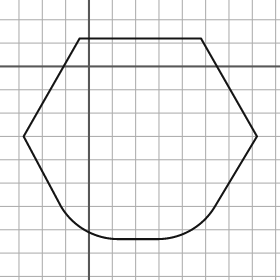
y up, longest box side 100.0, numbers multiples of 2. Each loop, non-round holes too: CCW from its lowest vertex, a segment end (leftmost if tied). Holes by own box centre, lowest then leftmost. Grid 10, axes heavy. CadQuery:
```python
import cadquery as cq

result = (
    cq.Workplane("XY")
    .moveTo(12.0, -74.0)
    .lineTo(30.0, -74.0)
    .threePointArc((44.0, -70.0), (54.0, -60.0))
    .lineTo(72.0, -30.0)
    .lineTo(48.0, 12.0)
    .lineTo(-4.0, 12.0)
    .lineTo(-28.0, -30.0)
    .lineTo(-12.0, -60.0)
    .threePointArc((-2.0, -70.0), (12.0, -74.0))
    .close()
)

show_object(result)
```